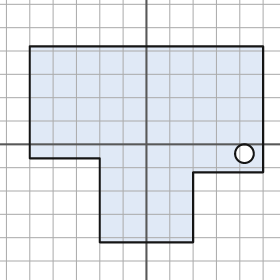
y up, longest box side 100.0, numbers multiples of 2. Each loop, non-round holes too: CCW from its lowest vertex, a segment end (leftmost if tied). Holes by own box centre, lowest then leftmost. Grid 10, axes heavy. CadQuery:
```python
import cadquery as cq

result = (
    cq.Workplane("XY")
    .moveTo(-20.0, -42.0)
    .lineTo(20.0, -42.0)
    .lineTo(20.0, -12.0)
    .lineTo(50.0, -12.0)
    .lineTo(50.0, 42.0)
    .lineTo(-50.0, 42.0)
    .lineTo(-50.0, -6.0)
    .lineTo(-20.0, -6.0)
    .close()
    .moveTo(42.0, -4.0)
    .circle(4.0)
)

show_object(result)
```